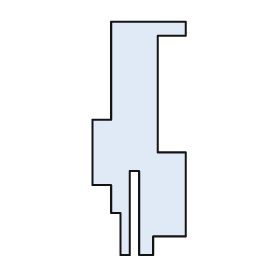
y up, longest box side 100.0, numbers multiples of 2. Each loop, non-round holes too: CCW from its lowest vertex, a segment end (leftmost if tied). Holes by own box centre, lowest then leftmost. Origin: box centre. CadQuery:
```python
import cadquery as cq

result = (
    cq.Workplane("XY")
    .moveTo(-8.0, -50.0)
    .lineTo(-4.0, -50.0)
    .lineTo(-4.0, -14.0)
    .lineTo(0.0, -14.0)
    .lineTo(0.0, -50.0)
    .lineTo(6.0, -50.0)
    .lineTo(6.0, -42.0)
    .lineTo(20.0, -42.0)
    .lineTo(20.0, -6.0)
    .lineTo(8.0, -6.0)
    .lineTo(8.0, 44.0)
    .lineTo(20.0, 44.0)
    .lineTo(20.0, 50.0)
    .lineTo(-12.0, 50.0)
    .lineTo(-12.0, 8.0)
    .lineTo(-20.0, 8.0)
    .lineTo(-20.0, -20.0)
    .lineTo(-12.0, -20.0)
    .lineTo(-12.0, -32.0)
    .lineTo(-8.0, -32.0)
    .close()
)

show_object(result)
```